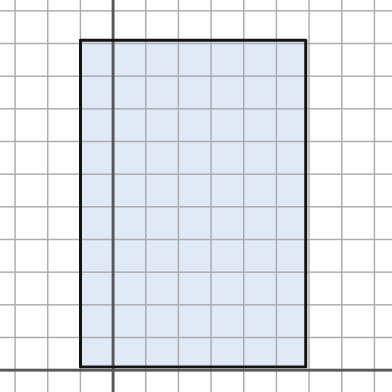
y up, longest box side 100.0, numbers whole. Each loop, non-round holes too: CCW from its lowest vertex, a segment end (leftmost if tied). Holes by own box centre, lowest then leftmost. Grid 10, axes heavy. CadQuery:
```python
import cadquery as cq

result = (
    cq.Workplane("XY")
    .moveTo(-10.0, 1.0)
    .lineTo(59.0, 1.0)
    .lineTo(59.0, 101.0)
    .lineTo(-10.0, 101.0)
    .close()
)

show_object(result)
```